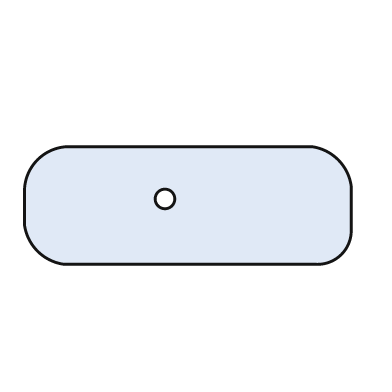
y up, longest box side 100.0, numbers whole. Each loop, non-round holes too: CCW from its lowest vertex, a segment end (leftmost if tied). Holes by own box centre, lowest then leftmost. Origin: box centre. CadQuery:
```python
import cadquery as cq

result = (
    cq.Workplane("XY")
    .moveTo(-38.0, -18.0)
    .lineTo(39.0, -18.0)
    .threePointArc((47.0, -15.0), (50.0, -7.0))
    .lineTo(50.0, 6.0)
    .threePointArc((46.0, 14.0), (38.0, 18.0))
    .lineTo(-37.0, 18.0)
    .threePointArc((-46.0, 14.0), (-50.0, 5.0))
    .lineTo(-50.0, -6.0)
    .threePointArc((-46.0, -14.0), (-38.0, -18.0))
    .close()
    .moveTo(-7.0, 2.0)
    .circle(3.0)
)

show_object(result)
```